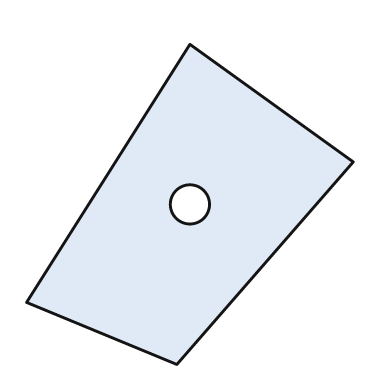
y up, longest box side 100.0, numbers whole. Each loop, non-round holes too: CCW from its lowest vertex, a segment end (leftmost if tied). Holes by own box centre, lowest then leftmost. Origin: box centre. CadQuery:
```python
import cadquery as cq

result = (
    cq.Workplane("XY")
    .moveTo(-4.0, -49.0)
    .lineTo(50.0, 13.0)
    .lineTo(0.0, 49.0)
    .lineTo(-50.0, -30.0)
    .close()
    .moveTo(0.0, 0.0)
    .circle(6.0)
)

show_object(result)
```